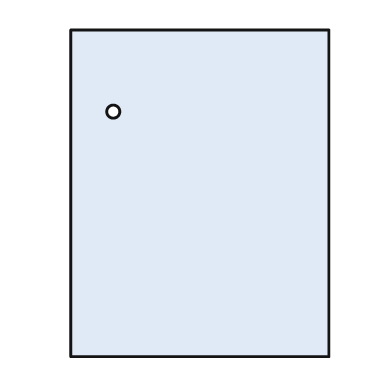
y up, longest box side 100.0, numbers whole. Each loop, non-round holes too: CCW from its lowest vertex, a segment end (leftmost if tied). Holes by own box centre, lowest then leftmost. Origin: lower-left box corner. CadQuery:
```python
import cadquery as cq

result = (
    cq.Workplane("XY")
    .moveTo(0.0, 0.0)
    .lineTo(79.0, 0.0)
    .lineTo(79.0, 100.0)
    .lineTo(0.0, 100.0)
    .close()
    .moveTo(13.0, 75.0)
    .circle(2.0)
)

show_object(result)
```